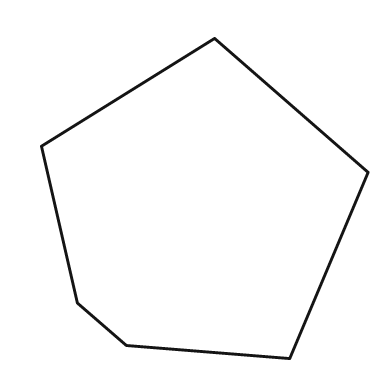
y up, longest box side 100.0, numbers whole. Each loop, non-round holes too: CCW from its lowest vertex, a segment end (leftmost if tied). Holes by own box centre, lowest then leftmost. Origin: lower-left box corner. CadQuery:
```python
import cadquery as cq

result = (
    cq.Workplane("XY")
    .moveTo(76.0, 0.0)
    .lineTo(100.0, 57.0)
    .lineTo(53.0, 98.0)
    .lineTo(0.0, 65.0)
    .lineTo(11.0, 17.0)
    .lineTo(26.0, 4.0)
    .close()
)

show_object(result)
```